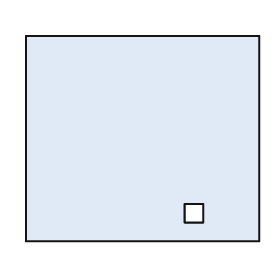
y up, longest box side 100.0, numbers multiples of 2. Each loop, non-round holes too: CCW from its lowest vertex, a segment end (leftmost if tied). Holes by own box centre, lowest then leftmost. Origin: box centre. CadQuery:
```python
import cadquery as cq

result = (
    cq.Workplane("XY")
    .moveTo(-50.0, -44.0)
    .lineTo(50.0, -44.0)
    .lineTo(50.0, 44.0)
    .lineTo(-50.0, 44.0)
    .close()
    .moveTo(18.0, -36.0)
    .lineTo(26.0, -36.0)
    .lineTo(26.0, -28.0)
    .lineTo(18.0, -28.0)
    .close()
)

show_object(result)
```